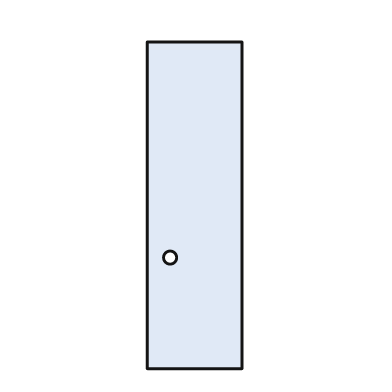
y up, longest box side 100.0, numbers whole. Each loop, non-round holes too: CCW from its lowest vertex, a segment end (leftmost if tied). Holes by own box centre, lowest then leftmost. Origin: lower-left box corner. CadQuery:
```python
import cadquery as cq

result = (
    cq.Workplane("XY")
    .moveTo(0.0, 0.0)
    .lineTo(29.0, 0.0)
    .lineTo(29.0, 100.0)
    .lineTo(0.0, 100.0)
    .close()
    .moveTo(7.0, 34.0)
    .circle(2.0)
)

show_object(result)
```